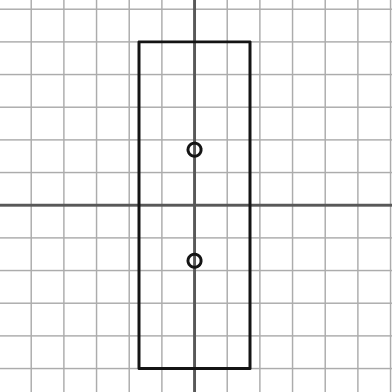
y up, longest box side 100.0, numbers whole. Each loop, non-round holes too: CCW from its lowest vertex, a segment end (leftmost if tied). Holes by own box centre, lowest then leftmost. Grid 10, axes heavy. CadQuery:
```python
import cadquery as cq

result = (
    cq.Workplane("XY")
    .moveTo(-17.0, -50.0)
    .lineTo(17.0, -50.0)
    .lineTo(17.0, 50.0)
    .lineTo(-17.0, 50.0)
    .close()
    .moveTo(0.0, -17.0)
    .circle(2.0)
    .moveTo(0.0, 17.0)
    .circle(2.0)
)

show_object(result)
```